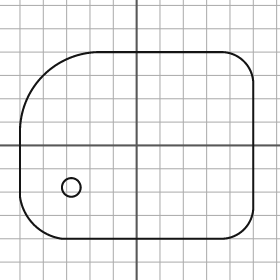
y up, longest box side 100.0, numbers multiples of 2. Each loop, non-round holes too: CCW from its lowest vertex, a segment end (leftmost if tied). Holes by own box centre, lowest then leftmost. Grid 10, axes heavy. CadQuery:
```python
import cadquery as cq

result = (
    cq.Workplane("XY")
    .moveTo(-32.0, -40.0)
    .lineTo(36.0, -40.0)
    .threePointArc((46.0, -36.0), (50.0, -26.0))
    .lineTo(50.0, 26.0)
    .threePointArc((46.0, 36.0), (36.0, 40.0))
    .lineTo(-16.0, 40.0)
    .threePointArc((-40.0, 30.0), (-50.0, 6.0))
    .lineTo(-50.0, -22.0)
    .threePointArc((-44.0, -34.0), (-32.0, -40.0))
    .close()
    .moveTo(-28.0, -18.0)
    .circle(4.0)
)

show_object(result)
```